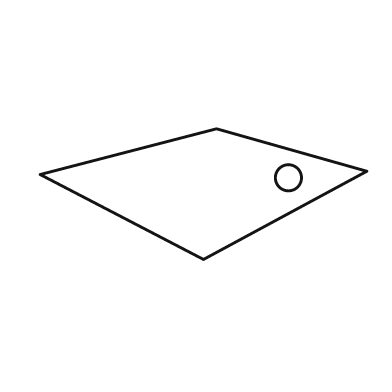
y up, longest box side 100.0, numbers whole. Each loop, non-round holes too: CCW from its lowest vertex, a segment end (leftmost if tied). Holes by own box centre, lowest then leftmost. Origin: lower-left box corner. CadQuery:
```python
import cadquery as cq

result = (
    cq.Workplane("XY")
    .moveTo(50.0, 0.0)
    .lineTo(100.0, 27.0)
    .lineTo(54.0, 40.0)
    .lineTo(0.0, 26.0)
    .close()
    .moveTo(76.0, 25.0)
    .circle(4.0)
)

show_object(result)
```